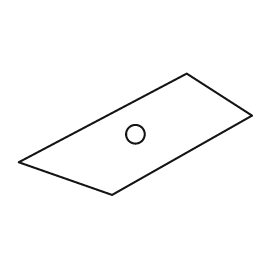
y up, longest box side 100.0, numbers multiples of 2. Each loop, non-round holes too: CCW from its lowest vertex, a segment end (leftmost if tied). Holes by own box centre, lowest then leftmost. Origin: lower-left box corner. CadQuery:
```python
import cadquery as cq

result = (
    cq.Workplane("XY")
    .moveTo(40.0, 0.0)
    .lineTo(100.0, 34.0)
    .lineTo(72.0, 52.0)
    .lineTo(0.0, 14.0)
    .close()
    .moveTo(50.0, 26.0)
    .circle(4.0)
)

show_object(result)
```